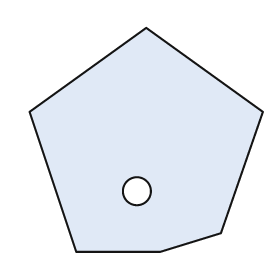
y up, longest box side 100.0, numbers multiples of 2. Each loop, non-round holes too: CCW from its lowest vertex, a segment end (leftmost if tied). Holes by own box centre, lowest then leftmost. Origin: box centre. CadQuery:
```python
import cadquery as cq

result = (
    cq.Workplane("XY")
    .moveTo(-30.0, -48.0)
    .lineTo(6.0, -48.0)
    .lineTo(32.0, -40.0)
    .lineTo(50.0, 12.0)
    .lineTo(0.0, 48.0)
    .lineTo(-50.0, 12.0)
    .close()
    .moveTo(-4.0, -22.0)
    .circle(6.0)
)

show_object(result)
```